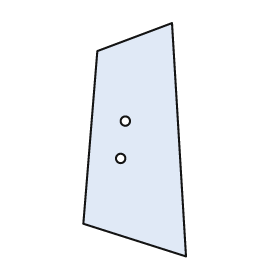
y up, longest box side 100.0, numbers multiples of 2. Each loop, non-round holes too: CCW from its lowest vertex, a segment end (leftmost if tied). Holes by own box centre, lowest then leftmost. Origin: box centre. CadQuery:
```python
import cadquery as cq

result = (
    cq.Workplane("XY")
    .moveTo(22.0, -50.0)
    .lineTo(16.0, 50.0)
    .lineTo(-16.0, 38.0)
    .lineTo(-22.0, -36.0)
    .close()
    .moveTo(-6.0, -8.0)
    .circle(2.0)
    .moveTo(-4.0, 8.0)
    .circle(2.0)
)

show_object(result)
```